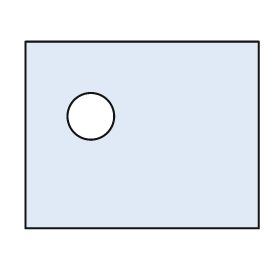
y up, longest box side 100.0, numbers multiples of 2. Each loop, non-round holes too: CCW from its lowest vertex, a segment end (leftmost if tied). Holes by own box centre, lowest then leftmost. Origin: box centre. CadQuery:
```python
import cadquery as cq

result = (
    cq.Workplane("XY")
    .moveTo(-50.0, -40.0)
    .lineTo(50.0, -40.0)
    .lineTo(50.0, 40.0)
    .lineTo(-50.0, 40.0)
    .close()
    .moveTo(-22.0, 8.0)
    .circle(10.0)
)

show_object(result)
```